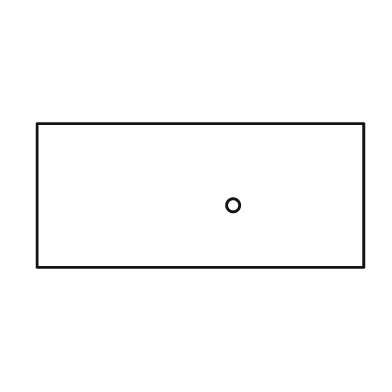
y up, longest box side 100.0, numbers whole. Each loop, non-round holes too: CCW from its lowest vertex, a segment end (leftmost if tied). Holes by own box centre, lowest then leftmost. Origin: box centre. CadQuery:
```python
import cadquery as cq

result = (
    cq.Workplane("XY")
    .moveTo(-50.0, -22.0)
    .lineTo(50.0, -22.0)
    .lineTo(50.0, 22.0)
    .lineTo(-50.0, 22.0)
    .close()
    .moveTo(10.0, -3.0)
    .circle(2.0)
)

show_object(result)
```